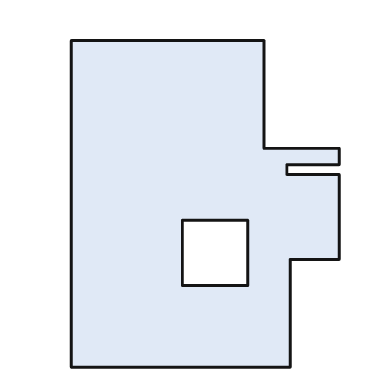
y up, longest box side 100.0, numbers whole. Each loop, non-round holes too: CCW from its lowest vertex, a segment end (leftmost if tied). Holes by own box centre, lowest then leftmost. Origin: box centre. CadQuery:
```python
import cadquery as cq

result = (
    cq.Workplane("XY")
    .moveTo(-41.0, -50.0)
    .lineTo(26.0, -50.0)
    .lineTo(26.0, -17.0)
    .lineTo(41.0, -17.0)
    .lineTo(41.0, 9.0)
    .lineTo(25.0, 9.0)
    .lineTo(25.0, 12.0)
    .lineTo(41.0, 12.0)
    .lineTo(41.0, 17.0)
    .lineTo(18.0, 17.0)
    .lineTo(18.0, 50.0)
    .lineTo(-41.0, 50.0)
    .close()
    .moveTo(-7.0, -25.0)
    .lineTo(13.0, -25.0)
    .lineTo(13.0, -5.0)
    .lineTo(-7.0, -5.0)
    .close()
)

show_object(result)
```